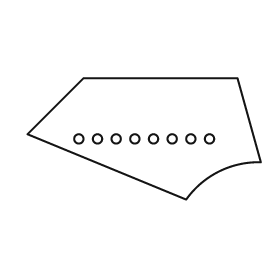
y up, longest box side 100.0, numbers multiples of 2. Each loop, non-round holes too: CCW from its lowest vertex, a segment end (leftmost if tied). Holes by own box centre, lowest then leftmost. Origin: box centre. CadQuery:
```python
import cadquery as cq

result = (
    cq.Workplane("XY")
    .moveTo(18.0, -26.0)
    .threePointArc((32.0, -14.0), (50.0, -10.0))
    .lineTo(40.0, 26.0)
    .lineTo(-26.0, 26.0)
    .lineTo(-50.0, 2.0)
    .close()
    .moveTo(-28.0, 0.0)
    .circle(2.0)
    .moveTo(-20.0, 0.0)
    .circle(2.0)
    .moveTo(-12.0, 0.0)
    .circle(2.0)
    .moveTo(-4.0, 0.0)
    .circle(2.0)
    .moveTo(4.0, 0.0)
    .circle(2.0)
    .moveTo(12.0, 0.0)
    .circle(2.0)
    .moveTo(20.0, 0.0)
    .circle(2.0)
    .moveTo(28.0, 0.0)
    .circle(2.0)
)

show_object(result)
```